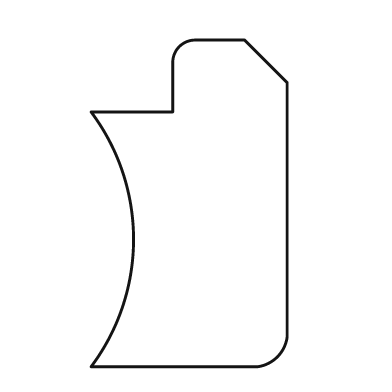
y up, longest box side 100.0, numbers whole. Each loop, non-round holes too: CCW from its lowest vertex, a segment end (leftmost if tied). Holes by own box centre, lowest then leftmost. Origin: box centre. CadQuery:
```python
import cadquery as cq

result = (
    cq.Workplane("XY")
    .moveTo(-30.0, -50.0)
    .lineTo(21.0, -50.0)
    .threePointArc((27.0, -47.0), (30.0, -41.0))
    .lineTo(30.0, 37.0)
    .lineTo(17.0, 50.0)
    .lineTo(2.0, 50.0)
    .threePointArc((-3.0, 48.0), (-5.0, 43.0))
    .lineTo(-5.0, 28.0)
    .lineTo(-30.0, 28.0)
    .threePointArc((-17.0, -11.0), (-30.0, -50.0))
    .close()
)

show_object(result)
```